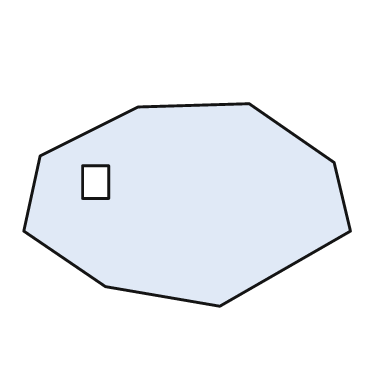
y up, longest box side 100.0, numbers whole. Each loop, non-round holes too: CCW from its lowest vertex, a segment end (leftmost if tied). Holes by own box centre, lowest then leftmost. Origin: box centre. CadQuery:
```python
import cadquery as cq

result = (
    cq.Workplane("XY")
    .moveTo(10.0, -31.0)
    .lineTo(50.0, -8.0)
    .lineTo(45.0, 13.0)
    .lineTo(19.0, 31.0)
    .lineTo(-15.0, 30.0)
    .lineTo(-45.0, 15.0)
    .lineTo(-50.0, -8.0)
    .lineTo(-25.0, -25.0)
    .close()
    .moveTo(-32.0, 2.0)
    .lineTo(-24.0, 2.0)
    .lineTo(-24.0, 12.0)
    .lineTo(-32.0, 12.0)
    .close()
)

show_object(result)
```